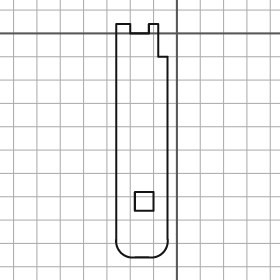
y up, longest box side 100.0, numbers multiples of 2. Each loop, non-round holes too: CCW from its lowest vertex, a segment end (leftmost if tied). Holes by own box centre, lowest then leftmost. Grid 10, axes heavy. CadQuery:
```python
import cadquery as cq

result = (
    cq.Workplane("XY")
    .moveTo(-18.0, -96.0)
    .lineTo(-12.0, -96.0)
    .threePointArc((-6.0, -94.0), (-4.0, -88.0))
    .lineTo(-4.0, -10.0)
    .lineTo(-8.0, -10.0)
    .lineTo(-8.0, 4.0)
    .lineTo(-12.0, 4.0)
    .lineTo(-12.0, 0.0)
    .lineTo(-20.0, 0.0)
    .lineTo(-20.0, 4.0)
    .lineTo(-26.0, 4.0)
    .lineTo(-26.0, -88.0)
    .threePointArc((-24.0, -94.0), (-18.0, -96.0))
    .close()
    .moveTo(-18.0, -76.0)
    .lineTo(-10.0, -76.0)
    .lineTo(-10.0, -68.0)
    .lineTo(-18.0, -68.0)
    .close()
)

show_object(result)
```